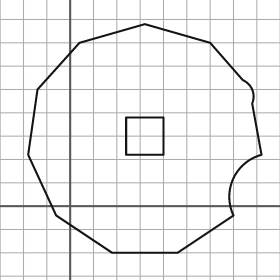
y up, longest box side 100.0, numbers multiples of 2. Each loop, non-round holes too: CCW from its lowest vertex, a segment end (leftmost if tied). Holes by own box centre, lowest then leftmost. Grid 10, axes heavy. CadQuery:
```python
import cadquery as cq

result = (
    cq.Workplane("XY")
    .moveTo(18.0, -20.0)
    .lineTo(46.0, -20.0)
    .lineTo(70.0, -4.0)
    .threePointArc((70.0, 12.0), (82.0, 22.0))
    .lineTo(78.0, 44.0)
    .threePointArc((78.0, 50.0), (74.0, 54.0))
    .lineTo(60.0, 70.0)
    .lineTo(32.0, 78.0)
    .lineTo(4.0, 70.0)
    .lineTo(-14.0, 50.0)
    .lineTo(-18.0, 22.0)
    .lineTo(-6.0, -4.0)
    .close()
    .moveTo(24.0, 22.0)
    .lineTo(40.0, 22.0)
    .lineTo(40.0, 38.0)
    .lineTo(24.0, 38.0)
    .close()
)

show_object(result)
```